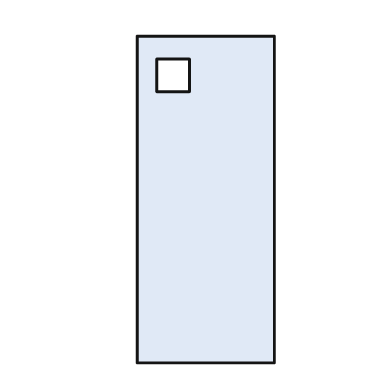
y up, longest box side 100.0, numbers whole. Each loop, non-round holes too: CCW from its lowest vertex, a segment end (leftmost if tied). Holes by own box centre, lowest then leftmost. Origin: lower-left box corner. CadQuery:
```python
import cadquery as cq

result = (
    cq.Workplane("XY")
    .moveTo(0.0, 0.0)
    .lineTo(42.0, 0.0)
    .lineTo(42.0, 100.0)
    .lineTo(0.0, 100.0)
    .close()
    .moveTo(6.0, 83.0)
    .lineTo(16.0, 83.0)
    .lineTo(16.0, 93.0)
    .lineTo(6.0, 93.0)
    .close()
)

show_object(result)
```